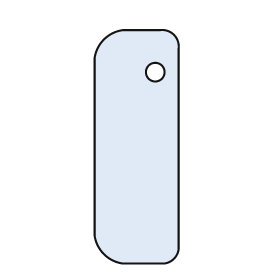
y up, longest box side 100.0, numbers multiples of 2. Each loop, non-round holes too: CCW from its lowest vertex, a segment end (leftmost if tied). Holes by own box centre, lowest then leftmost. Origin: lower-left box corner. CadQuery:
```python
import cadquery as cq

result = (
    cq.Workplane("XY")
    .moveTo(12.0, 0.0)
    .lineTo(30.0, 0.0)
    .threePointArc((34.0, 2.0), (36.0, 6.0))
    .lineTo(36.0, 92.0)
    .threePointArc((34.0, 98.0), (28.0, 100.0))
    .lineTo(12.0, 100.0)
    .threePointArc((4.0, 96.0), (0.0, 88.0))
    .lineTo(0.0, 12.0)
    .threePointArc((4.0, 4.0), (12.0, 0.0))
    .close()
    .moveTo(26.0, 82.0)
    .circle(4.0)
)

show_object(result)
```